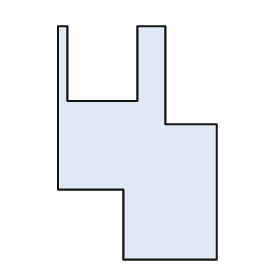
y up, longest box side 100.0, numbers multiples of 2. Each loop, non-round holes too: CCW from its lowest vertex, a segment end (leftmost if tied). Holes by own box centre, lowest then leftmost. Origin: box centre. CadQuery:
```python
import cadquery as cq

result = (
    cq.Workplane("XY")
    .moveTo(-6.0, -50.0)
    .lineTo(34.0, -50.0)
    .lineTo(34.0, 8.0)
    .lineTo(12.0, 8.0)
    .lineTo(12.0, 50.0)
    .lineTo(0.0, 50.0)
    .lineTo(0.0, 18.0)
    .lineTo(-30.0, 18.0)
    .lineTo(-30.0, 50.0)
    .lineTo(-34.0, 50.0)
    .lineTo(-34.0, -20.0)
    .lineTo(-6.0, -20.0)
    .close()
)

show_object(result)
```